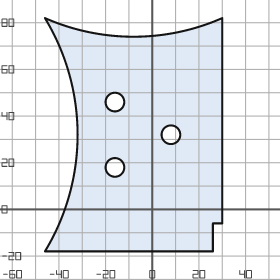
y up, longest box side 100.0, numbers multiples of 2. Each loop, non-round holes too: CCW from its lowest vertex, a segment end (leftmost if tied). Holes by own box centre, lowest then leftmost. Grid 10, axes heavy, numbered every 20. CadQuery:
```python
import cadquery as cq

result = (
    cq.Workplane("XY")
    .moveTo(-46.0, -18.0)
    .lineTo(26.0, -18.0)
    .lineTo(26.0, -6.0)
    .lineTo(30.0, -6.0)
    .lineTo(30.0, 82.0)
    .threePointArc((-8.0, 74.0), (-46.0, 82.0))
    .threePointArc((-32.0, 32.0), (-46.0, -18.0))
    .close()
    .moveTo(-16.0, 18.0)
    .circle(4.0)
    .moveTo(8.0, 32.0)
    .circle(4.0)
    .moveTo(-16.0, 46.0)
    .circle(4.0)
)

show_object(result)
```